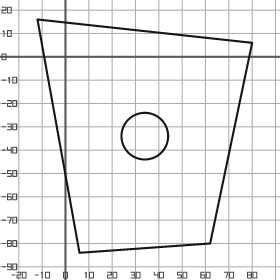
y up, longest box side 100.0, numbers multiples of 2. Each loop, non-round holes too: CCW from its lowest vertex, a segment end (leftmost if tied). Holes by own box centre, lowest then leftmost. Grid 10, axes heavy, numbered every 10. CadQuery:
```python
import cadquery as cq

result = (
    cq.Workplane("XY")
    .moveTo(6.0, -84.0)
    .lineTo(62.0, -80.0)
    .lineTo(80.0, 6.0)
    .lineTo(-12.0, 16.0)
    .close()
    .moveTo(34.0, -34.0)
    .circle(10.0)
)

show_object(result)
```